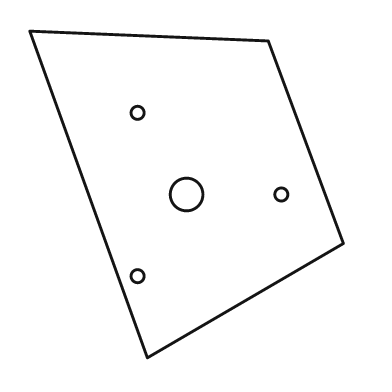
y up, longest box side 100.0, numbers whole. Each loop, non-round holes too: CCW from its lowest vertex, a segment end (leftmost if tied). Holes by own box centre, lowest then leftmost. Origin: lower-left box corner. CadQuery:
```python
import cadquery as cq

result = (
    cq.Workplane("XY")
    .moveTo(36.0, 0.0)
    .lineTo(96.0, 35.0)
    .lineTo(73.0, 97.0)
    .lineTo(0.0, 100.0)
    .close()
    .moveTo(33.0, 25.0)
    .circle(2.0)
    .moveTo(48.0, 50.0)
    .circle(5.0)
    .moveTo(77.0, 50.0)
    .circle(2.0)
    .moveTo(33.0, 75.0)
    .circle(2.0)
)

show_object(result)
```